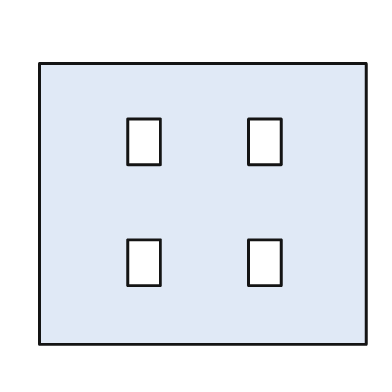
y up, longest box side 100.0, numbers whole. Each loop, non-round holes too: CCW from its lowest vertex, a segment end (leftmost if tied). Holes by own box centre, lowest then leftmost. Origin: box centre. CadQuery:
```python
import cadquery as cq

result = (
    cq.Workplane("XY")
    .moveTo(-50.0, -43.0)
    .lineTo(50.0, -43.0)
    .lineTo(50.0, 43.0)
    .lineTo(-50.0, 43.0)
    .close()
    .moveTo(-23.0, -25.0)
    .lineTo(-13.0, -25.0)
    .lineTo(-13.0, -11.0)
    .lineTo(-23.0, -11.0)
    .close()
    .moveTo(14.0, -25.0)
    .lineTo(24.0, -25.0)
    .lineTo(24.0, -11.0)
    .lineTo(14.0, -11.0)
    .close()
    .moveTo(-23.0, 12.0)
    .lineTo(-13.0, 12.0)
    .lineTo(-13.0, 26.0)
    .lineTo(-23.0, 26.0)
    .close()
    .moveTo(14.0, 12.0)
    .lineTo(24.0, 12.0)
    .lineTo(24.0, 26.0)
    .lineTo(14.0, 26.0)
    .close()
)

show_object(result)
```